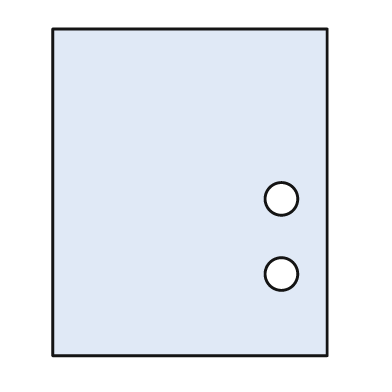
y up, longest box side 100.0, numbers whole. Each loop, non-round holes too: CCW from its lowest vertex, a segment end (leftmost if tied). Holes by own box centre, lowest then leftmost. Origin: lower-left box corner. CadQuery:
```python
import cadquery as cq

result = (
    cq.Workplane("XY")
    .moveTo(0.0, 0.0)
    .lineTo(84.0, 0.0)
    .lineTo(84.0, 100.0)
    .lineTo(0.0, 100.0)
    .close()
    .moveTo(70.0, 25.0)
    .circle(5.0)
    .moveTo(70.0, 48.0)
    .circle(5.0)
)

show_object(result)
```